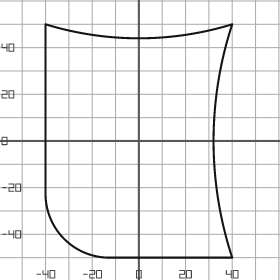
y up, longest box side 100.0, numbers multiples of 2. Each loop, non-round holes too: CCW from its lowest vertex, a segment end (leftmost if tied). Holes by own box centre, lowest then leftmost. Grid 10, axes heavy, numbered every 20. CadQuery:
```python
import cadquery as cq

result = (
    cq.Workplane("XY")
    .moveTo(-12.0, -50.0)
    .lineTo(40.0, -50.0)
    .threePointArc((32.0, 0.0), (40.0, 50.0))
    .threePointArc((0.0, 44.0), (-40.0, 50.0))
    .lineTo(-40.0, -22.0)
    .threePointArc((-32.0, -42.0), (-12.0, -50.0))
    .close()
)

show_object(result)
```